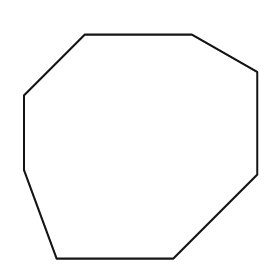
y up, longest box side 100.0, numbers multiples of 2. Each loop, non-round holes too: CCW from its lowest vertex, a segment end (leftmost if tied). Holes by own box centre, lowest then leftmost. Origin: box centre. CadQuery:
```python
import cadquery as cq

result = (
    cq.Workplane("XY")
    .moveTo(-36.0, -48.0)
    .lineTo(14.0, -48.0)
    .lineTo(50.0, -12.0)
    .lineTo(50.0, 32.0)
    .lineTo(22.0, 48.0)
    .lineTo(-24.0, 48.0)
    .lineTo(-50.0, 22.0)
    .lineTo(-50.0, -10.0)
    .close()
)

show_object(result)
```